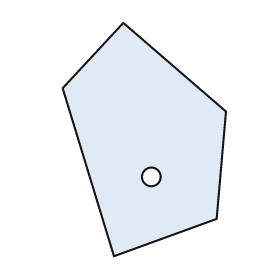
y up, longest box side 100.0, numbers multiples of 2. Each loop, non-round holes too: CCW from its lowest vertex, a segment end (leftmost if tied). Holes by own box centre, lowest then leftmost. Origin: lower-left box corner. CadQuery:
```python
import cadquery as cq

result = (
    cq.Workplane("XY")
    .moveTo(22.0, 0.0)
    .lineTo(66.0, 16.0)
    .lineTo(70.0, 62.0)
    .lineTo(26.0, 100.0)
    .lineTo(0.0, 72.0)
    .close()
    .moveTo(38.0, 34.0)
    .circle(4.0)
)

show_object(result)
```